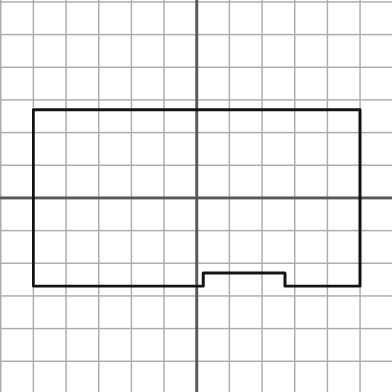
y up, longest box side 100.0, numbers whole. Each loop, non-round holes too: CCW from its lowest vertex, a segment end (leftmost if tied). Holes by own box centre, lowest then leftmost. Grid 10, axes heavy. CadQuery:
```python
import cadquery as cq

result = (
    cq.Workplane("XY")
    .moveTo(-50.0, -27.0)
    .lineTo(2.0, -27.0)
    .lineTo(2.0, -23.0)
    .lineTo(27.0, -23.0)
    .lineTo(27.0, -27.0)
    .lineTo(50.0, -27.0)
    .lineTo(50.0, 27.0)
    .lineTo(-50.0, 27.0)
    .close()
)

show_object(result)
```